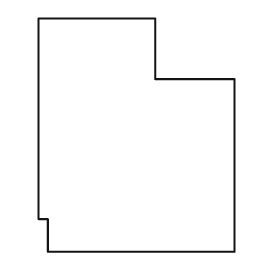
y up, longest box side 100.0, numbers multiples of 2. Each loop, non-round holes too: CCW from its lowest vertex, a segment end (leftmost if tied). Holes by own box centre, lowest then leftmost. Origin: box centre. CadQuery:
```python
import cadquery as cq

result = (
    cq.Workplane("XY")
    .moveTo(-38.0, -50.0)
    .lineTo(42.0, -50.0)
    .lineTo(42.0, 24.0)
    .lineTo(8.0, 24.0)
    .lineTo(8.0, 50.0)
    .lineTo(-42.0, 50.0)
    .lineTo(-42.0, -36.0)
    .lineTo(-38.0, -36.0)
    .close()
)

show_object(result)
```